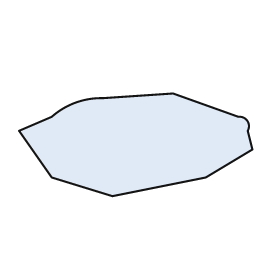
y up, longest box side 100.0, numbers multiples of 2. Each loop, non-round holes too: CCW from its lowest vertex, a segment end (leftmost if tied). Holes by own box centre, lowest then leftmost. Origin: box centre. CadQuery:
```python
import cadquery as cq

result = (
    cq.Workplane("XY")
    .moveTo(-10.0, -22.0)
    .lineTo(30.0, -14.0)
    .lineTo(50.0, -2.0)
    .lineTo(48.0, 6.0)
    .threePointArc((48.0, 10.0), (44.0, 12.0))
    .lineTo(16.0, 22.0)
    .lineTo(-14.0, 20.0)
    .threePointArc((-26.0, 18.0), (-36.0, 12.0))
    .lineTo(-50.0, 6.0)
    .lineTo(-36.0, -14.0)
    .close()
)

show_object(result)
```